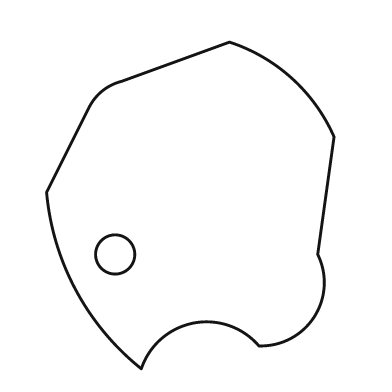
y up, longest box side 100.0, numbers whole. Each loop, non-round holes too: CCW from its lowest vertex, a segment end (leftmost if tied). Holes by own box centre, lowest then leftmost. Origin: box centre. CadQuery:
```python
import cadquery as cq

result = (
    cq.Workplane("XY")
    .moveTo(-15.0, -50.0)
    .threePointArc((1.0, -36.0), (21.0, -43.0))
    .threePointArc((38.0, -34.0), (39.0, -15.0))
    .lineTo(44.0, 21.0)
    .threePointArc((31.0, 39.0), (12.0, 50.0))
    .lineTo(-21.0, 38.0)
    .threePointArc((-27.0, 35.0), (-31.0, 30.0))
    .lineTo(-44.0, 4.0)
    .threePointArc((-35.0, -26.0), (-15.0, -50.0))
    .close()
    .moveTo(-23.0, -15.0)
    .circle(6.0)
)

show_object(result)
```